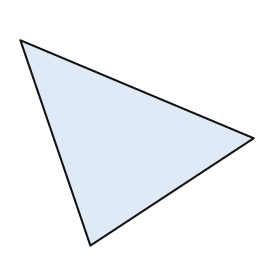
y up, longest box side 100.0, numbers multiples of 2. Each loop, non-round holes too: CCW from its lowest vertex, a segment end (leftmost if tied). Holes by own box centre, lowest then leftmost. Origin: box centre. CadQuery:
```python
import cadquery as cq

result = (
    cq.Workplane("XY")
    .moveTo(-20.0, -44.0)
    .lineTo(50.0, 2.0)
    .lineTo(-50.0, 44.0)
    .close()
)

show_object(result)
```